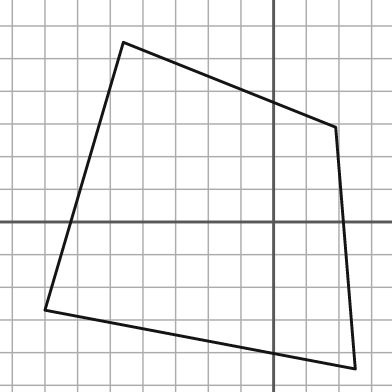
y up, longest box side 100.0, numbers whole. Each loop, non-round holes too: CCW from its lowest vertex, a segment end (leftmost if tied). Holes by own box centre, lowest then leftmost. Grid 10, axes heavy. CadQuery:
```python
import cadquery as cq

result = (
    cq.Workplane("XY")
    .moveTo(25.0, -45.0)
    .lineTo(19.0, 29.0)
    .lineTo(-46.0, 55.0)
    .lineTo(-70.0, -27.0)
    .close()
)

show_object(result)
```